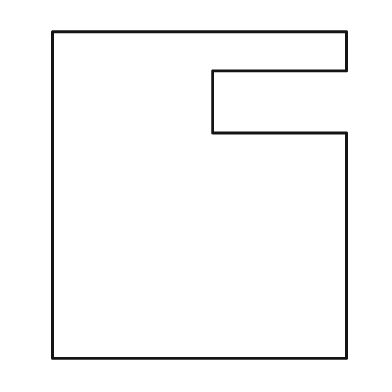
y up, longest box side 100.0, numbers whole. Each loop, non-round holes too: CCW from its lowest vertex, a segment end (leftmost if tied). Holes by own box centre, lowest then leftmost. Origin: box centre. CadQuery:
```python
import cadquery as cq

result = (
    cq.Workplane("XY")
    .moveTo(-45.0, -50.0)
    .lineTo(45.0, -50.0)
    .lineTo(45.0, 19.0)
    .lineTo(4.0, 19.0)
    .lineTo(4.0, 38.0)
    .lineTo(45.0, 38.0)
    .lineTo(45.0, 50.0)
    .lineTo(-45.0, 50.0)
    .close()
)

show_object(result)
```